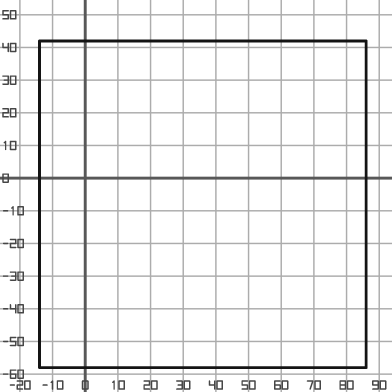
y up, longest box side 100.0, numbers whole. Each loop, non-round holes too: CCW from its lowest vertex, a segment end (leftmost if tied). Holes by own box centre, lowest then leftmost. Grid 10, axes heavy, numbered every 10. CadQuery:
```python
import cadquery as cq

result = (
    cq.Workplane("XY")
    .moveTo(-14.0, -58.0)
    .lineTo(86.0, -58.0)
    .lineTo(86.0, 42.0)
    .lineTo(-14.0, 42.0)
    .close()
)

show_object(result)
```